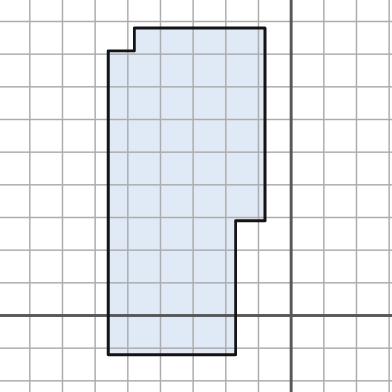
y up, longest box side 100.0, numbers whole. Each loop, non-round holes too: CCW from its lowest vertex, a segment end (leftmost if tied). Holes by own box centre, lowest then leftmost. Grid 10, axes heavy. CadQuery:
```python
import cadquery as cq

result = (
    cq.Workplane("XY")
    .moveTo(-56.0, -12.0)
    .lineTo(-17.0, -12.0)
    .lineTo(-17.0, 29.0)
    .lineTo(-8.0, 29.0)
    .lineTo(-8.0, 88.0)
    .lineTo(-48.0, 88.0)
    .lineTo(-48.0, 81.0)
    .lineTo(-56.0, 81.0)
    .close()
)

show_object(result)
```